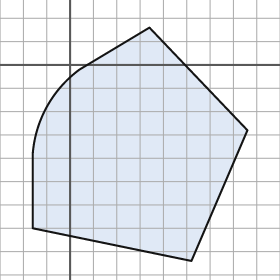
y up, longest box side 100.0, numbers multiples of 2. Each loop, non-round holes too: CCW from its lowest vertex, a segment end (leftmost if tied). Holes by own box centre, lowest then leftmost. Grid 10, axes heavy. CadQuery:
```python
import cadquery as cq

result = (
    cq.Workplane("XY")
    .moveTo(52.0, -84.0)
    .lineTo(76.0, -28.0)
    .lineTo(34.0, 16.0)
    .lineTo(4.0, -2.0)
    .threePointArc((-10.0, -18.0), (-16.0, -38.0))
    .lineTo(-16.0, -70.0)
    .close()
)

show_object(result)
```